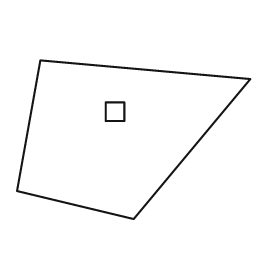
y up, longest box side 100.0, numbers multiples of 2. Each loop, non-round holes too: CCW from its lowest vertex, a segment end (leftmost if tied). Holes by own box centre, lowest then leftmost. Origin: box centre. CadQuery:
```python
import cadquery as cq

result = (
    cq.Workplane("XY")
    .moveTo(0.0, -34.0)
    .lineTo(50.0, 26.0)
    .lineTo(-40.0, 34.0)
    .lineTo(-50.0, -22.0)
    .close()
    .moveTo(-12.0, 8.0)
    .lineTo(-4.0, 8.0)
    .lineTo(-4.0, 16.0)
    .lineTo(-12.0, 16.0)
    .close()
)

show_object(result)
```